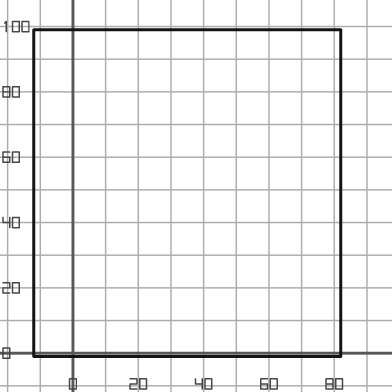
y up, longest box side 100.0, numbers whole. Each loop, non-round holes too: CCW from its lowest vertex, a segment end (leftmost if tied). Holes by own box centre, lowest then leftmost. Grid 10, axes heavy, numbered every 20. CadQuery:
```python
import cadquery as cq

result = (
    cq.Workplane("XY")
    .moveTo(-12.0, -1.0)
    .lineTo(82.0, -1.0)
    .lineTo(82.0, 99.0)
    .lineTo(-12.0, 99.0)
    .close()
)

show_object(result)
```